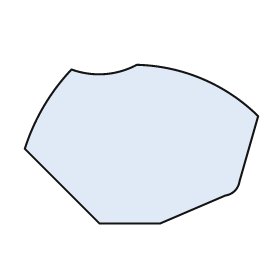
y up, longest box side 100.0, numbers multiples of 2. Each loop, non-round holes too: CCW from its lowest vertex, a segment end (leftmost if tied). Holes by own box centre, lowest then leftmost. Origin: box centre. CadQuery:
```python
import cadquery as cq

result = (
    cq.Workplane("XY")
    .moveTo(-18.0, -34.0)
    .lineTo(8.0, -34.0)
    .lineTo(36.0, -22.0)
    .threePointArc((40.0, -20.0), (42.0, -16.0))
    .lineTo(50.0, 12.0)
    .threePointArc((26.0, 28.0), (-2.0, 34.0))
    .threePointArc((-16.0, 30.0), (-30.0, 32.0))
    .threePointArc((-42.0, 16.0), (-50.0, -2.0))
    .close()
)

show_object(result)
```